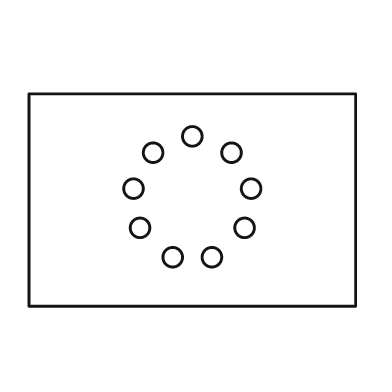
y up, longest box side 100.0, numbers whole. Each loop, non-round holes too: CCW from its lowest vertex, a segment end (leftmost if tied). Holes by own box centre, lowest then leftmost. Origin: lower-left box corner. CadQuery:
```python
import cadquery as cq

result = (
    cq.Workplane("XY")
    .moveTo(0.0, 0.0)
    .lineTo(100.0, 0.0)
    .lineTo(100.0, 65.0)
    .lineTo(0.0, 65.0)
    .close()
    .moveTo(44.0, 15.0)
    .circle(3.0)
    .moveTo(56.0, 15.0)
    .circle(3.0)
    .moveTo(34.0, 24.0)
    .circle(3.0)
    .moveTo(66.0, 24.0)
    .circle(3.0)
    .moveTo(32.0, 36.0)
    .circle(3.0)
    .moveTo(68.0, 36.0)
    .circle(3.0)
    .moveTo(38.0, 47.0)
    .circle(3.0)
    .moveTo(62.0, 47.0)
    .circle(3.0)
    .moveTo(50.0, 52.0)
    .circle(3.0)
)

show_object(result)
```